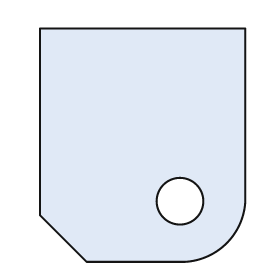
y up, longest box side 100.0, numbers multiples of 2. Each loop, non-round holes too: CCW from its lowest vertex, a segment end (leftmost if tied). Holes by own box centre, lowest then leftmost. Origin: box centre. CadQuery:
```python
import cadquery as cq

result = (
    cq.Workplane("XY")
    .moveTo(-24.0, -50.0)
    .lineTo(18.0, -50.0)
    .threePointArc((36.0, -42.0), (44.0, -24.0))
    .lineTo(44.0, 50.0)
    .lineTo(-44.0, 50.0)
    .lineTo(-44.0, -30.0)
    .close()
    .moveTo(16.0, -24.0)
    .circle(10.0)
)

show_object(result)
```